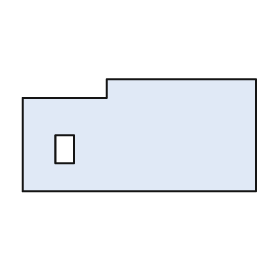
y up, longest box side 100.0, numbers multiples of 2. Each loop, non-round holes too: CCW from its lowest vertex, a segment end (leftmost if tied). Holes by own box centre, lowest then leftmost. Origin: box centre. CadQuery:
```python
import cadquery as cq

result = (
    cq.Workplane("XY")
    .moveTo(-50.0, -24.0)
    .lineTo(50.0, -24.0)
    .lineTo(50.0, 24.0)
    .lineTo(-14.0, 24.0)
    .lineTo(-14.0, 16.0)
    .lineTo(-50.0, 16.0)
    .close()
    .moveTo(-36.0, -12.0)
    .lineTo(-28.0, -12.0)
    .lineTo(-28.0, 0.0)
    .lineTo(-36.0, 0.0)
    .close()
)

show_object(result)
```